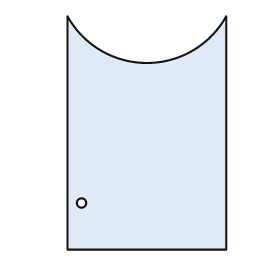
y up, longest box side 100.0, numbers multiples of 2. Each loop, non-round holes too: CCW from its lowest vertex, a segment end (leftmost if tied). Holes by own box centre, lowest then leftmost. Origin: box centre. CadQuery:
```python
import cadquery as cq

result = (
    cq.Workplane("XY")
    .moveTo(-34.0, -50.0)
    .lineTo(34.0, -50.0)
    .lineTo(34.0, 50.0)
    .threePointArc((0.0, 30.0), (-34.0, 50.0))
    .close()
    .moveTo(-28.0, -30.0)
    .circle(2.0)
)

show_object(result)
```